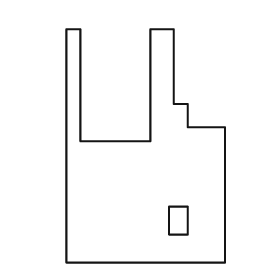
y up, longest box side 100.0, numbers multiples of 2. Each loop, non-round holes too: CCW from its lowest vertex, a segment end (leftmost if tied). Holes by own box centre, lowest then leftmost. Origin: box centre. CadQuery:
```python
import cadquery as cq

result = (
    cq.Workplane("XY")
    .moveTo(-34.0, -50.0)
    .lineTo(34.0, -50.0)
    .lineTo(34.0, 8.0)
    .lineTo(18.0, 8.0)
    .lineTo(18.0, 18.0)
    .lineTo(12.0, 18.0)
    .lineTo(12.0, 50.0)
    .lineTo(2.0, 50.0)
    .lineTo(2.0, 2.0)
    .lineTo(-28.0, 2.0)
    .lineTo(-28.0, 50.0)
    .lineTo(-34.0, 50.0)
    .close()
    .moveTo(10.0, -38.0)
    .lineTo(18.0, -38.0)
    .lineTo(18.0, -26.0)
    .lineTo(10.0, -26.0)
    .close()
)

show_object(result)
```